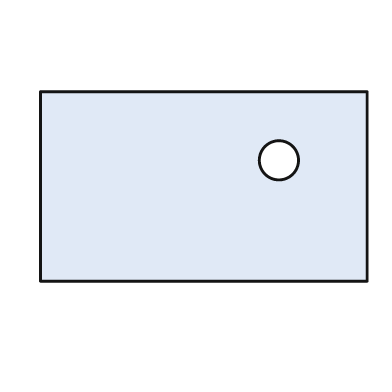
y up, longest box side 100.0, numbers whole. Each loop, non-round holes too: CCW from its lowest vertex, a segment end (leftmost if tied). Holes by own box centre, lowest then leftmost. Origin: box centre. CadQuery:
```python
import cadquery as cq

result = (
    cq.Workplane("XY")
    .moveTo(-50.0, -29.0)
    .lineTo(50.0, -29.0)
    .lineTo(50.0, 29.0)
    .lineTo(-50.0, 29.0)
    .close()
    .moveTo(23.0, 8.0)
    .circle(6.0)
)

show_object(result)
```